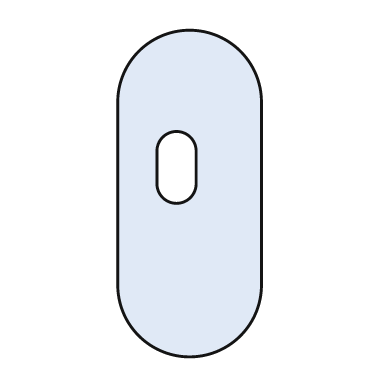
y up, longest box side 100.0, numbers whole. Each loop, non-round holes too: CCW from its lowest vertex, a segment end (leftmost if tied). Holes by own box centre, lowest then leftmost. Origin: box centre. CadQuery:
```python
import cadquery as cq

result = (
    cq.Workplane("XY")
    .moveTo(-22.0, -28.0)
    .threePointArc((0.0, -50.0), (22.0, -28.0))
    .lineTo(22.0, 28.0)
    .threePointArc((0.0, 50.0), (-22.0, 28.0))
    .close()
    .moveTo(-10.0, 3.0)
    .threePointArc((-4.0, -3.0), (2.0, 3.0))
    .lineTo(2.0, 13.0)
    .threePointArc((-4.0, 19.0), (-10.0, 13.0))
    .close()
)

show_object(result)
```